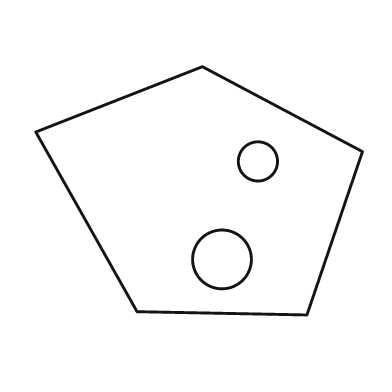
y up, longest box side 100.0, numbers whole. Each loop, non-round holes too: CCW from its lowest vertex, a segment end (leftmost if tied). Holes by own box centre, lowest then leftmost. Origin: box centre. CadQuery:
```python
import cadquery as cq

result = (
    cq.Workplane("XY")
    .moveTo(33.0, -38.0)
    .lineTo(50.0, 12.0)
    .lineTo(1.0, 38.0)
    .lineTo(-50.0, 18.0)
    .lineTo(-19.0, -37.0)
    .close()
    .moveTo(7.0, -21.0)
    .circle(9.0)
    .moveTo(18.0, 9.0)
    .circle(6.0)
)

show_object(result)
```